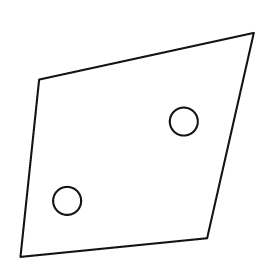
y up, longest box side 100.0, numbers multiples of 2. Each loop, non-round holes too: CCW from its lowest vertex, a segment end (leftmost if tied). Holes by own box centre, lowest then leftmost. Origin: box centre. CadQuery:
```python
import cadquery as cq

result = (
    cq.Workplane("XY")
    .moveTo(-50.0, -48.0)
    .lineTo(30.0, -40.0)
    .lineTo(50.0, 48.0)
    .lineTo(-42.0, 28.0)
    .close()
    .moveTo(-30.0, -24.0)
    .circle(6.0)
    .moveTo(20.0, 10.0)
    .circle(6.0)
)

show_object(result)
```